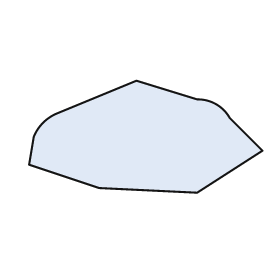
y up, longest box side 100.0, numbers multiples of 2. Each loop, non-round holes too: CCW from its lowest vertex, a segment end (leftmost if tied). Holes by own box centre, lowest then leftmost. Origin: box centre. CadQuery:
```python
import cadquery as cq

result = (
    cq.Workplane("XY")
    .moveTo(22.0, -24.0)
    .lineTo(50.0, -6.0)
    .lineTo(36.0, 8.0)
    .threePointArc((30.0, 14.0), (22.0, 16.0))
    .lineTo(-4.0, 24.0)
    .lineTo(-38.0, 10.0)
    .threePointArc((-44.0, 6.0), (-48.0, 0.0))
    .lineTo(-50.0, -12.0)
    .lineTo(-20.0, -22.0)
    .close()
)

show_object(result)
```